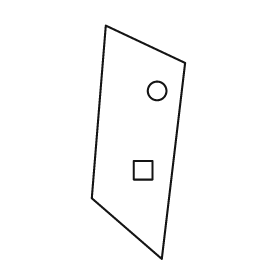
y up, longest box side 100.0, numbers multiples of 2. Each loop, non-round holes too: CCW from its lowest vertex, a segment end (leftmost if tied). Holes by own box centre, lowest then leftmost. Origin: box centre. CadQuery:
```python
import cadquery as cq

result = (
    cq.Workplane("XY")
    .moveTo(10.0, -50.0)
    .lineTo(20.0, 34.0)
    .lineTo(-14.0, 50.0)
    .lineTo(-20.0, -24.0)
    .close()
    .moveTo(-2.0, -16.0)
    .lineTo(6.0, -16.0)
    .lineTo(6.0, -8.0)
    .lineTo(-2.0, -8.0)
    .close()
    .moveTo(8.0, 22.0)
    .circle(4.0)
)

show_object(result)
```